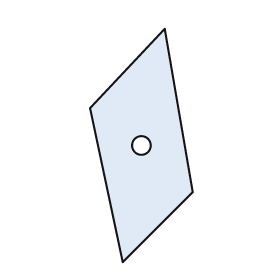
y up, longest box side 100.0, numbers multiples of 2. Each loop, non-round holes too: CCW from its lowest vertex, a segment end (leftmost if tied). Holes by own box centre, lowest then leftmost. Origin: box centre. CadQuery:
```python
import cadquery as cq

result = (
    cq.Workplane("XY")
    .moveTo(-8.0, -50.0)
    .lineTo(22.0, -20.0)
    .lineTo(10.0, 50.0)
    .lineTo(-22.0, 16.0)
    .close()
    .moveTo(0.0, 0.0)
    .circle(4.0)
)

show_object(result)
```